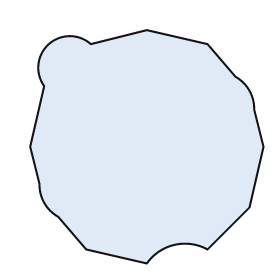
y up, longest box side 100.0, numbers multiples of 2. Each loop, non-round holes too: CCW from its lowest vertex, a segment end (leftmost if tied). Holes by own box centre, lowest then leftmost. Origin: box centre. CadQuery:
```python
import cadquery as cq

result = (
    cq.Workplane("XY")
    .moveTo(0.0, -50.0)
    .threePointArc((12.0, -42.0), (26.0, -44.0))
    .lineTo(44.0, -26.0)
    .lineTo(50.0, 0.0)
    .lineTo(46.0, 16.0)
    .threePointArc((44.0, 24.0), (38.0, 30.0))
    .lineTo(26.0, 44.0)
    .lineTo(0.0, 50.0)
    .lineTo(-24.0, 44.0)
    .threePointArc((-42.0, 44.0), (-44.0, 26.0))
    .lineTo(-50.0, 0.0)
    .lineTo(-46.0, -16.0)
    .threePointArc((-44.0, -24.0), (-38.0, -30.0))
    .lineTo(-26.0, -44.0)
    .close()
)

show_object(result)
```